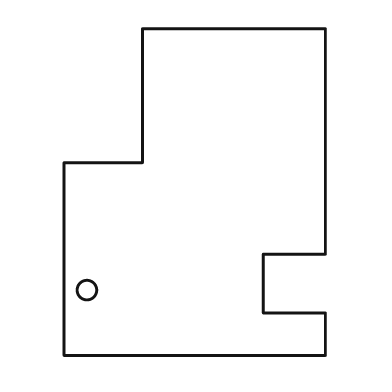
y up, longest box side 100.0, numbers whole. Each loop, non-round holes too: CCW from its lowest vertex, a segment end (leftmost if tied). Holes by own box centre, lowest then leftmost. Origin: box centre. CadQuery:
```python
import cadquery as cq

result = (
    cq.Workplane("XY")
    .moveTo(-40.0, -50.0)
    .lineTo(40.0, -50.0)
    .lineTo(40.0, -37.0)
    .lineTo(21.0, -37.0)
    .lineTo(21.0, -19.0)
    .lineTo(40.0, -19.0)
    .lineTo(40.0, 50.0)
    .lineTo(-16.0, 50.0)
    .lineTo(-16.0, 9.0)
    .lineTo(-40.0, 9.0)
    .close()
    .moveTo(-33.0, -30.0)
    .circle(3.0)
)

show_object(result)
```